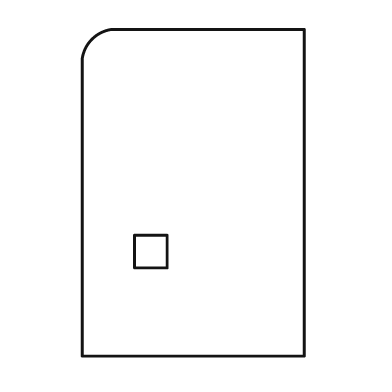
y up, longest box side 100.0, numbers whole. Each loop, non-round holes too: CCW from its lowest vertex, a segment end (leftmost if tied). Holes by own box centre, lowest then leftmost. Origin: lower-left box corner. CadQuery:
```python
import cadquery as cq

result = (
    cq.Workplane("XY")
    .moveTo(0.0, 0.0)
    .lineTo(68.0, 0.0)
    .lineTo(68.0, 100.0)
    .lineTo(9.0, 100.0)
    .threePointArc((3.0, 97.0), (0.0, 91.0))
    .close()
    .moveTo(16.0, 27.0)
    .lineTo(26.0, 27.0)
    .lineTo(26.0, 37.0)
    .lineTo(16.0, 37.0)
    .close()
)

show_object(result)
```